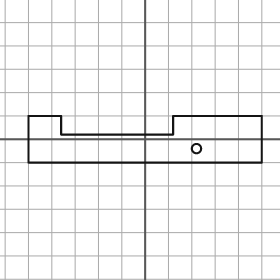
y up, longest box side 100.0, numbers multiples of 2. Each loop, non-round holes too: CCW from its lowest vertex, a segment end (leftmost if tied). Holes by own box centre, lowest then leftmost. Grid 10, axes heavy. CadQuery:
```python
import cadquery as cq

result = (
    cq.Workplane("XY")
    .moveTo(-50.0, -10.0)
    .lineTo(50.0, -10.0)
    .lineTo(50.0, 10.0)
    .lineTo(12.0, 10.0)
    .lineTo(12.0, 2.0)
    .lineTo(-36.0, 2.0)
    .lineTo(-36.0, 10.0)
    .lineTo(-50.0, 10.0)
    .close()
    .moveTo(22.0, -4.0)
    .circle(2.0)
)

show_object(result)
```